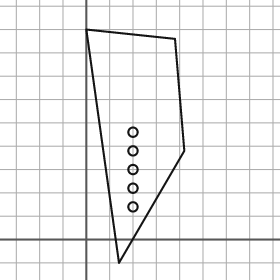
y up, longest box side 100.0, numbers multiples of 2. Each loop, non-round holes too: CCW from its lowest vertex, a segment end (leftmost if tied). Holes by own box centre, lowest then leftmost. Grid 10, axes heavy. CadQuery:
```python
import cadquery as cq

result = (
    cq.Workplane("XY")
    .moveTo(14.0, -10.0)
    .lineTo(42.0, 38.0)
    .lineTo(38.0, 86.0)
    .lineTo(0.0, 90.0)
    .close()
    .moveTo(20.0, 14.0)
    .circle(2.0)
    .moveTo(20.0, 22.0)
    .circle(2.0)
    .moveTo(20.0, 30.0)
    .circle(2.0)
    .moveTo(20.0, 38.0)
    .circle(2.0)
    .moveTo(20.0, 46.0)
    .circle(2.0)
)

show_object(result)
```